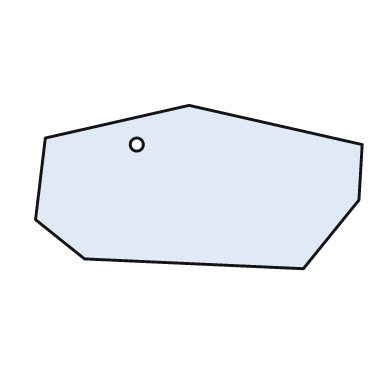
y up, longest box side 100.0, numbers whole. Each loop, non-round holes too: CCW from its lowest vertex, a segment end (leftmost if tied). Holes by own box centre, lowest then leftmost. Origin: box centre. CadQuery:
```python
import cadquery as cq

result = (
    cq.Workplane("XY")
    .moveTo(32.0, -25.0)
    .lineTo(49.0, -4.0)
    .lineTo(50.0, 13.0)
    .lineTo(-3.0, 25.0)
    .lineTo(-47.0, 15.0)
    .lineTo(-50.0, -10.0)
    .lineTo(-35.0, -22.0)
    .close()
    .moveTo(-19.0, 13.0)
    .circle(2.0)
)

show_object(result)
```